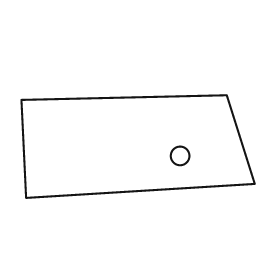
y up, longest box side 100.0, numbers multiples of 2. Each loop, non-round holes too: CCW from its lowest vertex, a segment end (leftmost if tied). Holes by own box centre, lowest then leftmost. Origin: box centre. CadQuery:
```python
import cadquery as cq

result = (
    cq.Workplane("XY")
    .moveTo(-48.0, -22.0)
    .lineTo(50.0, -16.0)
    .lineTo(38.0, 22.0)
    .lineTo(-50.0, 20.0)
    .close()
    .moveTo(18.0, -4.0)
    .circle(4.0)
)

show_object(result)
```